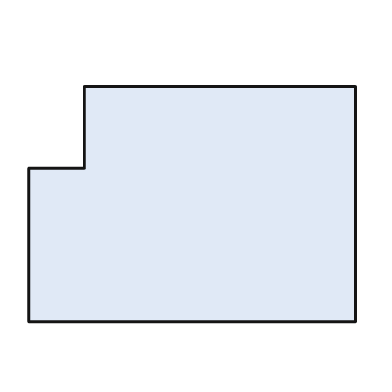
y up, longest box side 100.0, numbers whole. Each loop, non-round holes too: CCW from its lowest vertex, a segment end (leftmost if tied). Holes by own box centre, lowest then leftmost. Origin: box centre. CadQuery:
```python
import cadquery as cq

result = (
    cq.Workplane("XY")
    .moveTo(-50.0, -36.0)
    .lineTo(50.0, -36.0)
    .lineTo(50.0, 36.0)
    .lineTo(-33.0, 36.0)
    .lineTo(-33.0, 11.0)
    .lineTo(-50.0, 11.0)
    .close()
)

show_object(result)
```